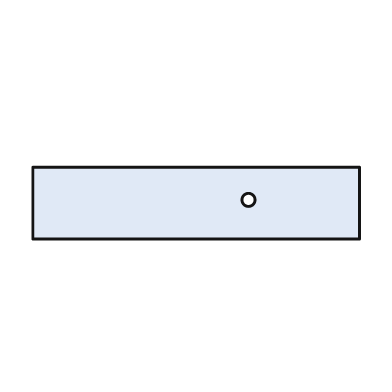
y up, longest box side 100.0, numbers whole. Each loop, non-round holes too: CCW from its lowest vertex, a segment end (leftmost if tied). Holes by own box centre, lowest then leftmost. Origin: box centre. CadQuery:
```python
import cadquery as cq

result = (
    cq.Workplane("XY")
    .moveTo(-50.0, -11.0)
    .lineTo(50.0, -11.0)
    .lineTo(50.0, 11.0)
    .lineTo(-50.0, 11.0)
    .close()
    .moveTo(16.0, 1.0)
    .circle(2.0)
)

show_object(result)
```